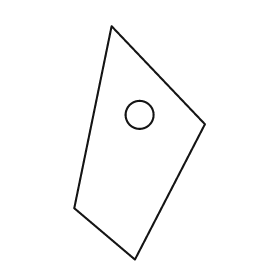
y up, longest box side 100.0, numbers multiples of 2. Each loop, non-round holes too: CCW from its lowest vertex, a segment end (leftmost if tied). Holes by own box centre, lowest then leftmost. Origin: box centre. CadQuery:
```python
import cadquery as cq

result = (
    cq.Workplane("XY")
    .moveTo(-2.0, -50.0)
    .lineTo(28.0, 8.0)
    .lineTo(-12.0, 50.0)
    .lineTo(-28.0, -28.0)
    .close()
    .moveTo(0.0, 12.0)
    .circle(6.0)
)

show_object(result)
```